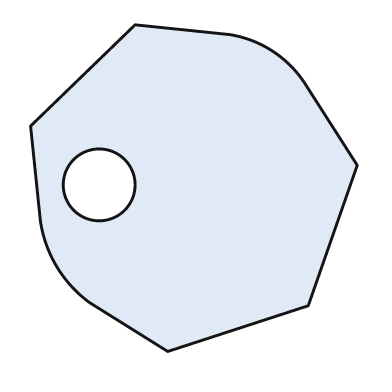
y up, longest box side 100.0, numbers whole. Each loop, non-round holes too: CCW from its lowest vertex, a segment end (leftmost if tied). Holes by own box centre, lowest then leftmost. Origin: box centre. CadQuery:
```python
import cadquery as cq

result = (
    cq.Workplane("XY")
    .moveTo(-8.0, -50.0)
    .lineTo(35.0, -36.0)
    .lineTo(50.0, 7.0)
    .lineTo(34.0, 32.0)
    .threePointArc((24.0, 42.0), (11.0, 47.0))
    .lineTo(-18.0, 50.0)
    .lineTo(-50.0, 19.0)
    .lineTo(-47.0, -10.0)
    .threePointArc((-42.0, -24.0), (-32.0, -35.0))
    .close()
    .moveTo(-29.0, 1.0)
    .circle(11.0)
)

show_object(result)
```